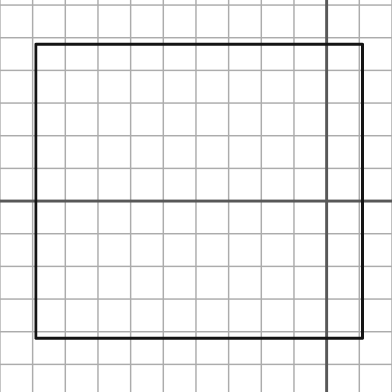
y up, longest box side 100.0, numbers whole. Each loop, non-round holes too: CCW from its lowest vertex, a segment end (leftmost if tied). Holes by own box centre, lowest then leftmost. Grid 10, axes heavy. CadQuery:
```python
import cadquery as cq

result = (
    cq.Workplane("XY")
    .moveTo(-89.0, -42.0)
    .lineTo(11.0, -42.0)
    .lineTo(11.0, 48.0)
    .lineTo(-89.0, 48.0)
    .close()
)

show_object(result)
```